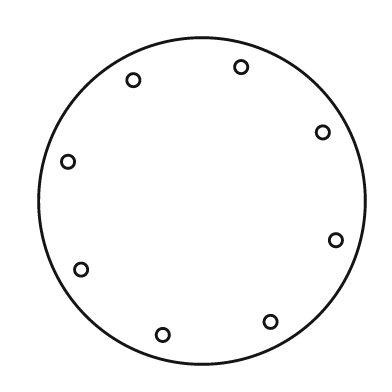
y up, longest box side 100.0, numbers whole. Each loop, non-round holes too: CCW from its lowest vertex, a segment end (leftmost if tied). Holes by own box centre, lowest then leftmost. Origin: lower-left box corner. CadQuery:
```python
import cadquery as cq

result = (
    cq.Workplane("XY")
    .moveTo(50.0, 50.0)
    .circle(50.0)
    .moveTo(38.0, 9.0)
    .circle(2.0)
    .moveTo(71.0, 13.0)
    .circle(2.0)
    .moveTo(13.0, 29.0)
    .circle(2.0)
    .moveTo(91.0, 38.0)
    .circle(2.0)
    .moveTo(9.0, 62.0)
    .circle(2.0)
    .moveTo(87.0, 71.0)
    .circle(2.0)
    .moveTo(29.0, 87.0)
    .circle(2.0)
    .moveTo(62.0, 91.0)
    .circle(2.0)
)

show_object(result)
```